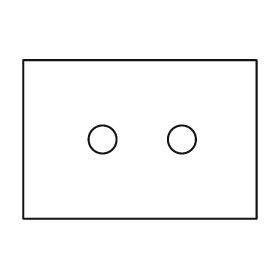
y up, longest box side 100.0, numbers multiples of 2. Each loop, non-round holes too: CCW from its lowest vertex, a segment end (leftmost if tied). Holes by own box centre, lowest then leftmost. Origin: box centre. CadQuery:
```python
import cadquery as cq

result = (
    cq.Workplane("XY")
    .moveTo(-50.0, -34.0)
    .lineTo(50.0, -34.0)
    .lineTo(50.0, 34.0)
    .lineTo(-50.0, 34.0)
    .close()
    .moveTo(-16.0, 0.0)
    .circle(6.0)
    .moveTo(18.0, 0.0)
    .circle(6.0)
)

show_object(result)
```